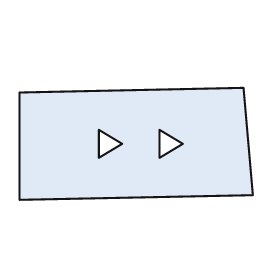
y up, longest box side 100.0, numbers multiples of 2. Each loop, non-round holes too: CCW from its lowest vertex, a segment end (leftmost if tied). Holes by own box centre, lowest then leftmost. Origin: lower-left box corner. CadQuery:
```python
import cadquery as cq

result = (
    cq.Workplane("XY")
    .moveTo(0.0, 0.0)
    .lineTo(100.0, 2.0)
    .lineTo(96.0, 48.0)
    .lineTo(0.0, 46.0)
    .close()
    .moveTo(34.0, 18.0)
    .lineTo(44.0, 24.0)
    .lineTo(34.0, 30.0)
    .close()
    .moveTo(60.0, 18.0)
    .lineTo(70.0, 24.0)
    .lineTo(60.0, 30.0)
    .close()
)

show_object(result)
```